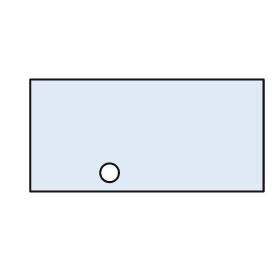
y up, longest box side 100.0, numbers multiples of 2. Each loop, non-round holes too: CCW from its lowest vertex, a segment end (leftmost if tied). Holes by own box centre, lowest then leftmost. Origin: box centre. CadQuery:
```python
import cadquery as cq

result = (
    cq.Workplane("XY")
    .moveTo(-50.0, -24.0)
    .lineTo(50.0, -24.0)
    .lineTo(50.0, 24.0)
    .lineTo(-50.0, 24.0)
    .close()
    .moveTo(-16.0, -16.0)
    .circle(4.0)
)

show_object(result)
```